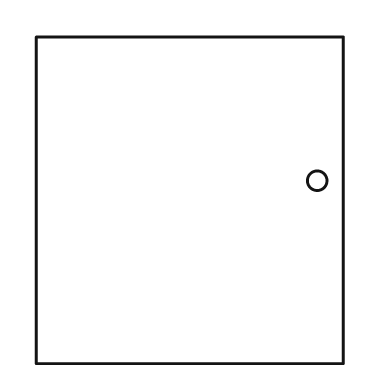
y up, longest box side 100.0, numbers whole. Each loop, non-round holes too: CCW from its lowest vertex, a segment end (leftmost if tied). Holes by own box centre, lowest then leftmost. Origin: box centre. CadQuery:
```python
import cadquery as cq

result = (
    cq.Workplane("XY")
    .moveTo(-47.0, -50.0)
    .lineTo(47.0, -50.0)
    .lineTo(47.0, 50.0)
    .lineTo(-47.0, 50.0)
    .close()
    .moveTo(39.0, 6.0)
    .circle(3.0)
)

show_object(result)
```